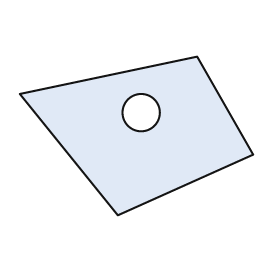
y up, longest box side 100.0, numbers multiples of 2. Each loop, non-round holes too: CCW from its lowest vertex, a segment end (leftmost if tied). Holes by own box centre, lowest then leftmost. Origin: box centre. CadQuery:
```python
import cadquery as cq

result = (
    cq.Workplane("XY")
    .moveTo(-8.0, -34.0)
    .lineTo(50.0, -8.0)
    .lineTo(26.0, 34.0)
    .lineTo(-50.0, 18.0)
    .close()
    .moveTo(2.0, 10.0)
    .circle(8.0)
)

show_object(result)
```